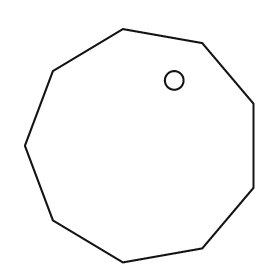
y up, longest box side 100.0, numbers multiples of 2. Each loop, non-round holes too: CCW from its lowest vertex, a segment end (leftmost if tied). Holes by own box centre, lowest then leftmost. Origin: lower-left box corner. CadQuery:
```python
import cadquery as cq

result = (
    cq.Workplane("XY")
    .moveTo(42.0, 0.0)
    .lineTo(76.0, 6.0)
    .lineTo(98.0, 32.0)
    .lineTo(98.0, 68.0)
    .lineTo(76.0, 94.0)
    .lineTo(42.0, 100.0)
    .lineTo(12.0, 82.0)
    .lineTo(0.0, 50.0)
    .lineTo(12.0, 18.0)
    .close()
    .moveTo(64.0, 78.0)
    .circle(4.0)
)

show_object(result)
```